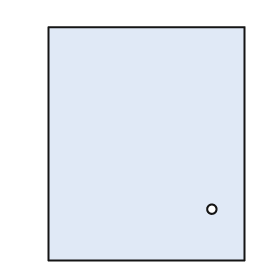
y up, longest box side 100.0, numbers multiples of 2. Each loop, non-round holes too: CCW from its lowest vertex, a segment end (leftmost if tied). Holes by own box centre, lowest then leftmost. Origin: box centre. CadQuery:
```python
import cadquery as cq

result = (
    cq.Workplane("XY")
    .moveTo(-42.0, -50.0)
    .lineTo(42.0, -50.0)
    .lineTo(42.0, 50.0)
    .lineTo(-42.0, 50.0)
    .close()
    .moveTo(28.0, -28.0)
    .circle(2.0)
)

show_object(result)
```